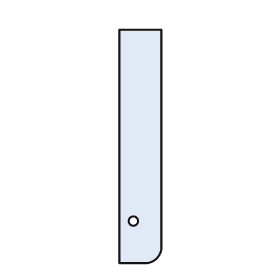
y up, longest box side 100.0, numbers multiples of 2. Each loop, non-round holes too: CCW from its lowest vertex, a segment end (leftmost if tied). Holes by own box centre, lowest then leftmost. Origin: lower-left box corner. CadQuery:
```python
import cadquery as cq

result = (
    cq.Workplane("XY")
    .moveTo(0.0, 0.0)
    .lineTo(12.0, 0.0)
    .threePointArc((16.0, 2.0), (18.0, 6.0))
    .lineTo(18.0, 100.0)
    .lineTo(0.0, 100.0)
    .close()
    .moveTo(6.0, 18.0)
    .circle(2.0)
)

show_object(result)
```